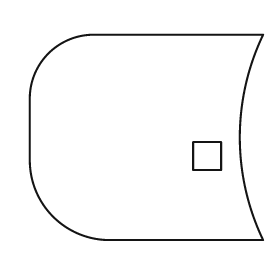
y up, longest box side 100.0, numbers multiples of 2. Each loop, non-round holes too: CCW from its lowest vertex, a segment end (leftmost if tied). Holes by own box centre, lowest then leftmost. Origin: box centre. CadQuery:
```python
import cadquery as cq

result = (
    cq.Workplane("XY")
    .moveTo(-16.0, -44.0)
    .lineTo(50.0, -44.0)
    .threePointArc((40.0, 0.0), (50.0, 44.0))
    .lineTo(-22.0, 44.0)
    .threePointArc((-42.0, 36.0), (-50.0, 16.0))
    .lineTo(-50.0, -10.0)
    .threePointArc((-40.0, -34.0), (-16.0, -44.0))
    .close()
    .moveTo(20.0, -14.0)
    .lineTo(32.0, -14.0)
    .lineTo(32.0, -2.0)
    .lineTo(20.0, -2.0)
    .close()
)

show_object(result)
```